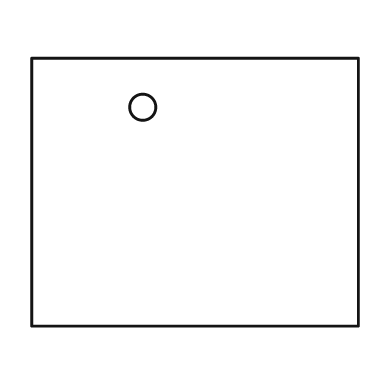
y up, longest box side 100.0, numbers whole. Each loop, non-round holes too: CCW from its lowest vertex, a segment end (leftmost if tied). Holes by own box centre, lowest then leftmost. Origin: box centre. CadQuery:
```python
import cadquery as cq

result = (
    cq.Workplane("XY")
    .moveTo(-50.0, -41.0)
    .lineTo(50.0, -41.0)
    .lineTo(50.0, 41.0)
    .lineTo(-50.0, 41.0)
    .close()
    .moveTo(-16.0, 26.0)
    .circle(4.0)
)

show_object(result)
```